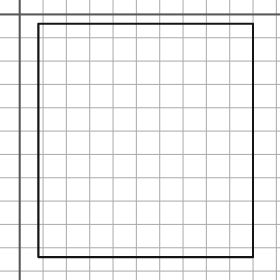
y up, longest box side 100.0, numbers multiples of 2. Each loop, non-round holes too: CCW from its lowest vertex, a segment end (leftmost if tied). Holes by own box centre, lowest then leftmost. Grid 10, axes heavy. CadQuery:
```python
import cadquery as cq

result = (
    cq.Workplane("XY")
    .moveTo(8.0, -104.0)
    .lineTo(100.0, -104.0)
    .lineTo(100.0, -4.0)
    .lineTo(8.0, -4.0)
    .close()
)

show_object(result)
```